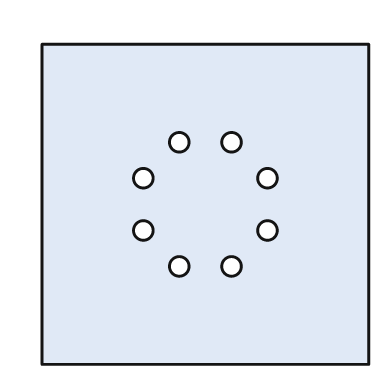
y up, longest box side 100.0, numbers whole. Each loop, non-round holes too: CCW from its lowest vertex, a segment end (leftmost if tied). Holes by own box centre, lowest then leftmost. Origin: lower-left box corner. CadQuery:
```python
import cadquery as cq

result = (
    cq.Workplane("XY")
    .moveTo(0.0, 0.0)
    .lineTo(100.0, 0.0)
    .lineTo(100.0, 98.0)
    .lineTo(0.0, 98.0)
    .close()
    .moveTo(42.0, 30.0)
    .circle(3.0)
    .moveTo(58.0, 30.0)
    .circle(3.0)
    .moveTo(31.0, 41.0)
    .circle(3.0)
    .moveTo(69.0, 41.0)
    .circle(3.0)
    .moveTo(31.0, 57.0)
    .circle(3.0)
    .moveTo(69.0, 57.0)
    .circle(3.0)
    .moveTo(42.0, 68.0)
    .circle(3.0)
    .moveTo(58.0, 68.0)
    .circle(3.0)
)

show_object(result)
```